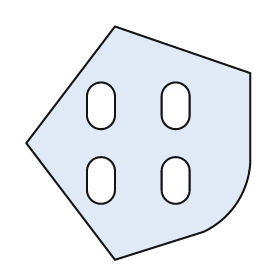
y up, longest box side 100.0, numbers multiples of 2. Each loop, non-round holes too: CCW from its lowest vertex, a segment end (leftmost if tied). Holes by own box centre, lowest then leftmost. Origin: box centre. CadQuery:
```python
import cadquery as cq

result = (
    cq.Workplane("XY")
    .moveTo(-10.0, -50.0)
    .lineTo(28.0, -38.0)
    .threePointArc((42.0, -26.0), (48.0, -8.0))
    .lineTo(48.0, 30.0)
    .lineTo(-10.0, 50.0)
    .lineTo(-48.0, 0.0)
    .close()
    .moveTo(-22.0, -20.0)
    .threePointArc((-16.0, -26.0), (-10.0, -20.0))
    .lineTo(-10.0, -12.0)
    .threePointArc((-16.0, -6.0), (-22.0, -12.0))
    .close()
    .moveTo(10.0, -20.0)
    .threePointArc((16.0, -26.0), (22.0, -20.0))
    .lineTo(22.0, -12.0)
    .threePointArc((16.0, -6.0), (10.0, -12.0))
    .close()
    .moveTo(-22.0, 12.0)
    .threePointArc((-16.0, 6.0), (-10.0, 12.0))
    .lineTo(-10.0, 20.0)
    .threePointArc((-16.0, 26.0), (-22.0, 20.0))
    .close()
    .moveTo(10.0, 12.0)
    .threePointArc((16.0, 6.0), (22.0, 12.0))
    .lineTo(22.0, 20.0)
    .threePointArc((16.0, 26.0), (10.0, 20.0))
    .close()
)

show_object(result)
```